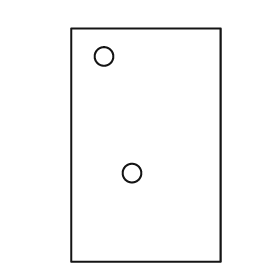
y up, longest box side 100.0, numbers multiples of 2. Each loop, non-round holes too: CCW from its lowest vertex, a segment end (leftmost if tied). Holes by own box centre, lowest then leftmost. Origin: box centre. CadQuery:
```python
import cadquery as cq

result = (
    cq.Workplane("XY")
    .moveTo(-32.0, -50.0)
    .lineTo(32.0, -50.0)
    .lineTo(32.0, 50.0)
    .lineTo(-32.0, 50.0)
    .close()
    .moveTo(-6.0, -12.0)
    .circle(4.0)
    .moveTo(-18.0, 38.0)
    .circle(4.0)
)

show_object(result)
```